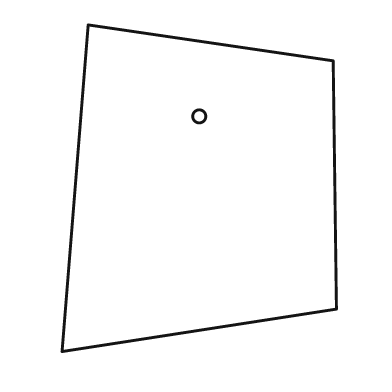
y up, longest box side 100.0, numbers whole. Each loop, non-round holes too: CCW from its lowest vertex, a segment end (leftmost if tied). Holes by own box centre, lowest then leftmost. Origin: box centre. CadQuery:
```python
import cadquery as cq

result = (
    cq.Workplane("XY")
    .moveTo(-42.0, -50.0)
    .lineTo(42.0, -37.0)
    .lineTo(41.0, 39.0)
    .lineTo(-34.0, 50.0)
    .close()
    .moveTo(0.0, 22.0)
    .circle(2.0)
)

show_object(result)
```